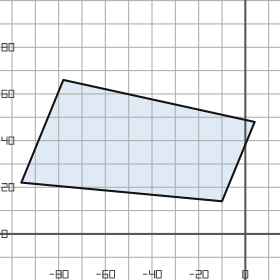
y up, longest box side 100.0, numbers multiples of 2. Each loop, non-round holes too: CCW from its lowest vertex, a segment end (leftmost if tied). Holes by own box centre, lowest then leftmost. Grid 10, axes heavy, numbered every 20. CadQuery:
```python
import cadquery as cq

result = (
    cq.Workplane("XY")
    .moveTo(-10.0, 14.0)
    .lineTo(4.0, 48.0)
    .lineTo(-78.0, 66.0)
    .lineTo(-96.0, 22.0)
    .close()
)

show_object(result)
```